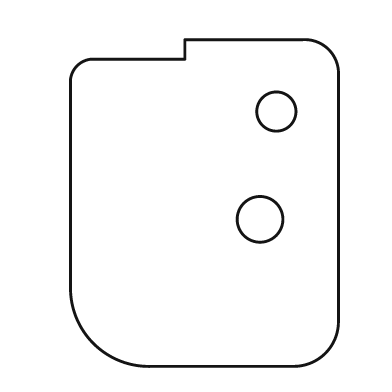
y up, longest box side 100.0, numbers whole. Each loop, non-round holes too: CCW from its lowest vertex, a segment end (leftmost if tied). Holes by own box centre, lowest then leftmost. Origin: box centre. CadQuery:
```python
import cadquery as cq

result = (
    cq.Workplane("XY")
    .moveTo(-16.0, -50.0)
    .lineTo(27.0, -50.0)
    .threePointArc((37.0, -46.0), (41.0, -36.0))
    .lineTo(41.0, 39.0)
    .threePointArc((38.0, 47.0), (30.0, 50.0))
    .lineTo(-6.0, 50.0)
    .lineTo(-6.0, 44.0)
    .lineTo(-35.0, 44.0)
    .threePointArc((-39.0, 42.0), (-41.0, 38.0))
    .lineTo(-41.0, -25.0)
    .threePointArc((-34.0, -43.0), (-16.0, -50.0))
    .close()
    .moveTo(17.0, -5.0)
    .circle(7.0)
    .moveTo(22.0, 28.0)
    .circle(6.0)
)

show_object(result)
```